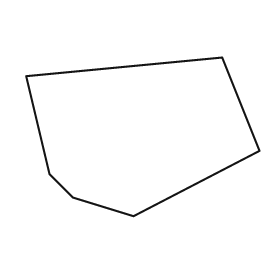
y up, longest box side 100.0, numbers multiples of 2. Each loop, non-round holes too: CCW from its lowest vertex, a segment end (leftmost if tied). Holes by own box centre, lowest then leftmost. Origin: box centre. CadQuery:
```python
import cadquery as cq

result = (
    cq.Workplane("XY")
    .moveTo(-4.0, -34.0)
    .lineTo(50.0, -6.0)
    .lineTo(34.0, 34.0)
    .lineTo(-50.0, 26.0)
    .lineTo(-40.0, -16.0)
    .lineTo(-30.0, -26.0)
    .close()
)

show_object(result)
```